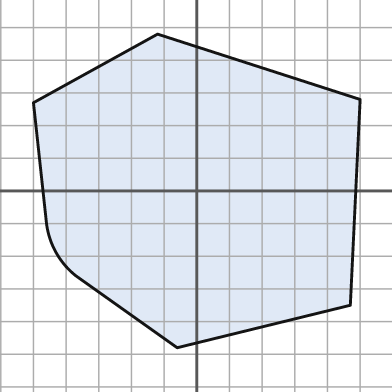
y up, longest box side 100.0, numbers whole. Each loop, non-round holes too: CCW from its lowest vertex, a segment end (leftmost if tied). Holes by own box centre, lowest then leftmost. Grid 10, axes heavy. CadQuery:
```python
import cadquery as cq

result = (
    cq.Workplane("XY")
    .moveTo(-6.0, -48.0)
    .lineTo(47.0, -35.0)
    .lineTo(50.0, 28.0)
    .lineTo(-12.0, 48.0)
    .lineTo(-50.0, 27.0)
    .lineTo(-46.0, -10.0)
    .threePointArc((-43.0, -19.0), (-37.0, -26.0))
    .close()
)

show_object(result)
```